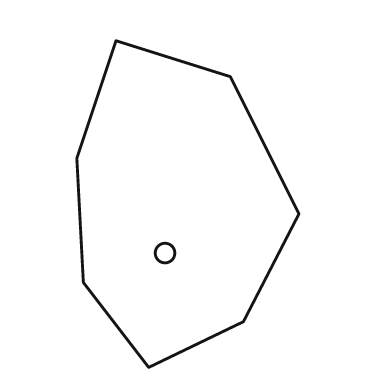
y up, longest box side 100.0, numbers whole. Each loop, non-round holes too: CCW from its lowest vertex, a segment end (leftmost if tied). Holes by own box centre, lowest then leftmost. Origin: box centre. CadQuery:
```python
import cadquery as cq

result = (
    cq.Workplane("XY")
    .moveTo(-12.0, -50.0)
    .lineTo(17.0, -36.0)
    .lineTo(34.0, -3.0)
    .lineTo(13.0, 39.0)
    .lineTo(-22.0, 50.0)
    .lineTo(-34.0, 14.0)
    .lineTo(-32.0, -24.0)
    .close()
    .moveTo(-7.0, -15.0)
    .circle(3.0)
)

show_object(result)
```